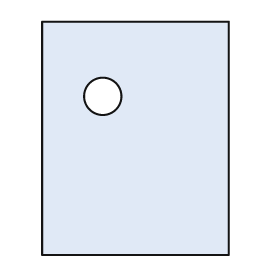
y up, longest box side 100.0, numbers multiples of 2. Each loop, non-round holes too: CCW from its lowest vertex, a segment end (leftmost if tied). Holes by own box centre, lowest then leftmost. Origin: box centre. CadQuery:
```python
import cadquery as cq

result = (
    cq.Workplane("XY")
    .moveTo(-40.0, -50.0)
    .lineTo(40.0, -50.0)
    .lineTo(40.0, 50.0)
    .lineTo(-40.0, 50.0)
    .close()
    .moveTo(-14.0, 18.0)
    .circle(8.0)
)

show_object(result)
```